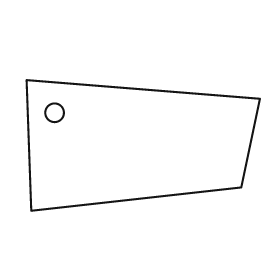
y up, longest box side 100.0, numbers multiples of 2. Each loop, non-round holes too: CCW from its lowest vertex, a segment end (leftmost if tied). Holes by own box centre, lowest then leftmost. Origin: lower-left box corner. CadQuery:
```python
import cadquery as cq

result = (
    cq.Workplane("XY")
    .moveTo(2.0, 0.0)
    .lineTo(92.0, 10.0)
    .lineTo(100.0, 48.0)
    .lineTo(0.0, 56.0)
    .close()
    .moveTo(12.0, 42.0)
    .circle(4.0)
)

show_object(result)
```